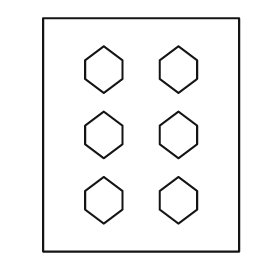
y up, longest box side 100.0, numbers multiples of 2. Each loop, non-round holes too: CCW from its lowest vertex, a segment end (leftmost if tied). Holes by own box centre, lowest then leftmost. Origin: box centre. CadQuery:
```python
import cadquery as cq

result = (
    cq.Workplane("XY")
    .moveTo(-42.0, -50.0)
    .lineTo(42.0, -50.0)
    .lineTo(42.0, 50.0)
    .lineTo(-42.0, 50.0)
    .close()
    .moveTo(-16.0, -38.0)
    .lineTo(-8.0, -32.0)
    .lineTo(-8.0, -24.0)
    .lineTo(-16.0, -18.0)
    .lineTo(-24.0, -24.0)
    .lineTo(-24.0, -32.0)
    .close()
    .moveTo(16.0, -38.0)
    .lineTo(24.0, -32.0)
    .lineTo(24.0, -24.0)
    .lineTo(16.0, -18.0)
    .lineTo(8.0, -24.0)
    .lineTo(8.0, -32.0)
    .close()
    .moveTo(-16.0, -10.0)
    .lineTo(-8.0, -4.0)
    .lineTo(-8.0, 4.0)
    .lineTo(-16.0, 10.0)
    .lineTo(-24.0, 4.0)
    .lineTo(-24.0, -4.0)
    .close()
    .moveTo(16.0, -10.0)
    .lineTo(24.0, -4.0)
    .lineTo(24.0, 4.0)
    .lineTo(16.0, 10.0)
    .lineTo(8.0, 4.0)
    .lineTo(8.0, -4.0)
    .close()
    .moveTo(-16.0, 18.0)
    .lineTo(-8.0, 24.0)
    .lineTo(-8.0, 32.0)
    .lineTo(-16.0, 38.0)
    .lineTo(-24.0, 32.0)
    .lineTo(-24.0, 24.0)
    .close()
    .moveTo(16.0, 18.0)
    .lineTo(24.0, 24.0)
    .lineTo(24.0, 32.0)
    .lineTo(16.0, 38.0)
    .lineTo(8.0, 32.0)
    .lineTo(8.0, 24.0)
    .close()
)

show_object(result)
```